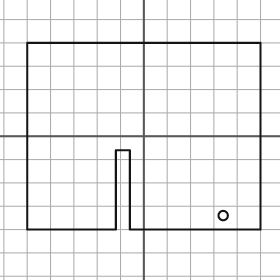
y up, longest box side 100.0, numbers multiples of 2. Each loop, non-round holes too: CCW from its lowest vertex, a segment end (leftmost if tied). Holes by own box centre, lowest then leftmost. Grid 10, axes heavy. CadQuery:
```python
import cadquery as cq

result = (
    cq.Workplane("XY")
    .moveTo(-50.0, -40.0)
    .lineTo(-12.0, -40.0)
    .lineTo(-12.0, -6.0)
    .lineTo(-6.0, -6.0)
    .lineTo(-6.0, -40.0)
    .lineTo(50.0, -40.0)
    .lineTo(50.0, 40.0)
    .lineTo(-50.0, 40.0)
    .close()
    .moveTo(34.0, -34.0)
    .circle(2.0)
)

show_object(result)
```